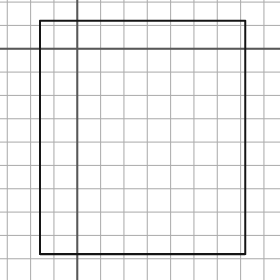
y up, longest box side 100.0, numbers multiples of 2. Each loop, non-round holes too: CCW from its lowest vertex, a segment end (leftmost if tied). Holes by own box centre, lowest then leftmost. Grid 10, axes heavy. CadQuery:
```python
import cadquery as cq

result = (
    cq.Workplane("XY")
    .moveTo(-16.0, -88.0)
    .lineTo(72.0, -88.0)
    .lineTo(72.0, 12.0)
    .lineTo(-16.0, 12.0)
    .close()
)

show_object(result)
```